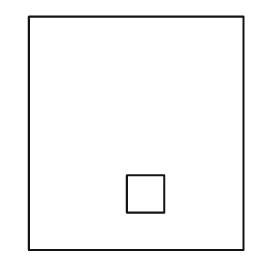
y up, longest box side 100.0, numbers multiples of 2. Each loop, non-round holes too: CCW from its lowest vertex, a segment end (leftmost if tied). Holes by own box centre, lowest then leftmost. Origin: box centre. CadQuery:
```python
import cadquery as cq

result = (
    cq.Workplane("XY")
    .moveTo(-46.0, -50.0)
    .lineTo(46.0, -50.0)
    .lineTo(46.0, 50.0)
    .lineTo(-46.0, 50.0)
    .close()
    .moveTo(-4.0, -34.0)
    .lineTo(12.0, -34.0)
    .lineTo(12.0, -18.0)
    .lineTo(-4.0, -18.0)
    .close()
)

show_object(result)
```